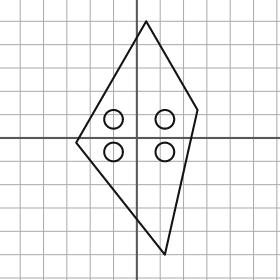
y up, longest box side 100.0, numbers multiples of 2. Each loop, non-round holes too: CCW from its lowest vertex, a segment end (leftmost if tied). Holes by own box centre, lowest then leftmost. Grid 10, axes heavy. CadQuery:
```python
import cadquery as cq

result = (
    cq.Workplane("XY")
    .moveTo(12.0, -50.0)
    .lineTo(26.0, 12.0)
    .lineTo(4.0, 50.0)
    .lineTo(-26.0, -2.0)
    .close()
    .moveTo(-10.0, -6.0)
    .circle(4.0)
    .moveTo(12.0, -6.0)
    .circle(4.0)
    .moveTo(-10.0, 8.0)
    .circle(4.0)
    .moveTo(12.0, 8.0)
    .circle(4.0)
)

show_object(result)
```